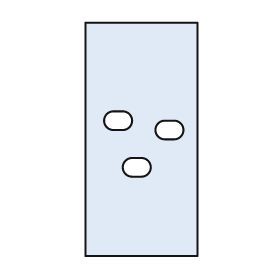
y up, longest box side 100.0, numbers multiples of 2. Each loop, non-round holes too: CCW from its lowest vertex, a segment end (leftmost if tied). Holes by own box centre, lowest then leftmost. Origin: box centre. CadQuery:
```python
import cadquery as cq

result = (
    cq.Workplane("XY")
    .moveTo(-24.0, -50.0)
    .lineTo(24.0, -50.0)
    .lineTo(24.0, 50.0)
    .lineTo(-24.0, 50.0)
    .close()
    .moveTo(-4.0, -16.0)
    .lineTo(0.0, -16.0)
    .threePointArc((4.0, -12.0), (0.0, -8.0))
    .lineTo(-4.0, -8.0)
    .threePointArc((-8.0, -12.0), (-4.0, -16.0))
    .close()
    .moveTo(10.0, 0.0)
    .lineTo(14.0, 0.0)
    .threePointArc((18.0, 4.0), (14.0, 8.0))
    .lineTo(10.0, 8.0)
    .threePointArc((6.0, 4.0), (10.0, 0.0))
    .close()
    .moveTo(-12.0, 4.0)
    .lineTo(-8.0, 4.0)
    .threePointArc((-4.0, 8.0), (-8.0, 12.0))
    .lineTo(-12.0, 12.0)
    .threePointArc((-16.0, 8.0), (-12.0, 4.0))
    .close()
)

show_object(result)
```